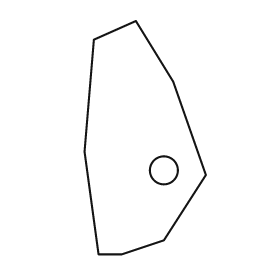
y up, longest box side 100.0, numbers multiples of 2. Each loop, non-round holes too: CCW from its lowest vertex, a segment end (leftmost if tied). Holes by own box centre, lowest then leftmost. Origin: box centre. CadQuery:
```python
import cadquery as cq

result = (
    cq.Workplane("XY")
    .moveTo(-20.0, -50.0)
    .lineTo(-10.0, -50.0)
    .lineTo(8.0, -44.0)
    .lineTo(26.0, -16.0)
    .lineTo(12.0, 24.0)
    .lineTo(-4.0, 50.0)
    .lineTo(-22.0, 42.0)
    .lineTo(-26.0, -6.0)
    .close()
    .moveTo(8.0, -14.0)
    .circle(6.0)
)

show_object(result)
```